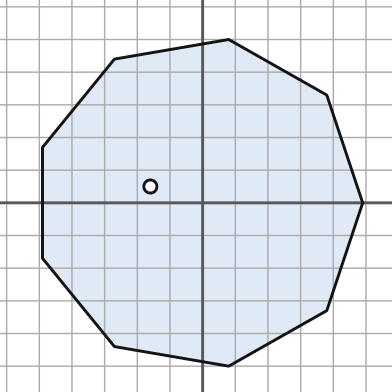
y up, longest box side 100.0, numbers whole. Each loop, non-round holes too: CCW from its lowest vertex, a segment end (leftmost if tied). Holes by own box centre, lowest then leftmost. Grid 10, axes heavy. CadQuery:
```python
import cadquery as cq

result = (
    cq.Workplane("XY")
    .moveTo(8.0, -50.0)
    .lineTo(38.0, -33.0)
    .lineTo(49.0, 0.0)
    .lineTo(38.0, 33.0)
    .lineTo(8.0, 50.0)
    .lineTo(-27.0, 44.0)
    .lineTo(-49.0, 17.0)
    .lineTo(-49.0, -17.0)
    .lineTo(-27.0, -44.0)
    .close()
    .moveTo(-16.0, 5.0)
    .circle(2.0)
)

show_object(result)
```